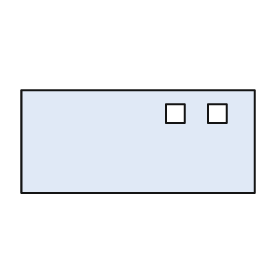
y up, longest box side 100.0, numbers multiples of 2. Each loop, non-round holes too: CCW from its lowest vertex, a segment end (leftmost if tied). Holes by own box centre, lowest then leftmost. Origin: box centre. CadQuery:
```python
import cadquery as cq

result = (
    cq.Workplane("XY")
    .moveTo(-50.0, -22.0)
    .lineTo(50.0, -22.0)
    .lineTo(50.0, 22.0)
    .lineTo(-50.0, 22.0)
    .close()
    .moveTo(12.0, 8.0)
    .lineTo(20.0, 8.0)
    .lineTo(20.0, 16.0)
    .lineTo(12.0, 16.0)
    .close()
    .moveTo(30.0, 8.0)
    .lineTo(38.0, 8.0)
    .lineTo(38.0, 16.0)
    .lineTo(30.0, 16.0)
    .close()
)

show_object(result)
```